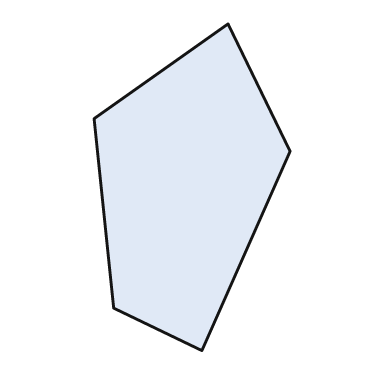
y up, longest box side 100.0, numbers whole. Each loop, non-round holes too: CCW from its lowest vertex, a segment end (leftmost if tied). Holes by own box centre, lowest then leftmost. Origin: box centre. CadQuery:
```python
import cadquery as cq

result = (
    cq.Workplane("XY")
    .moveTo(3.0, -50.0)
    .lineTo(30.0, 11.0)
    .lineTo(11.0, 50.0)
    .lineTo(-30.0, 21.0)
    .lineTo(-24.0, -37.0)
    .close()
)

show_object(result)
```